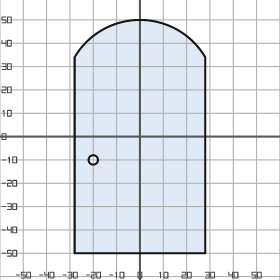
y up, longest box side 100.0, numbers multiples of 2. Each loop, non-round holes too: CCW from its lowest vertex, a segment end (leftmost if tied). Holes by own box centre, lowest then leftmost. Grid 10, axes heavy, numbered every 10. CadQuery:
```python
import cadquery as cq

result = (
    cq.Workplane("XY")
    .moveTo(-28.0, -50.0)
    .lineTo(28.0, -50.0)
    .lineTo(28.0, 34.0)
    .threePointArc((0.0, 50.0), (-28.0, 34.0))
    .close()
    .moveTo(-20.0, -10.0)
    .circle(2.0)
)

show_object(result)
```